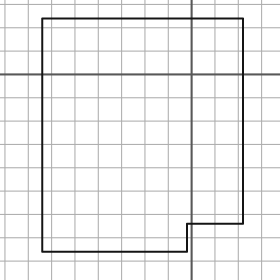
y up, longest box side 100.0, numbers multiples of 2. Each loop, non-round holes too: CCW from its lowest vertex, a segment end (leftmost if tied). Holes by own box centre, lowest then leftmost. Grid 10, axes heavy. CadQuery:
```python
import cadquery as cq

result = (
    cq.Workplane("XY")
    .moveTo(-64.0, -76.0)
    .lineTo(-2.0, -76.0)
    .lineTo(-2.0, -64.0)
    .lineTo(22.0, -64.0)
    .lineTo(22.0, 24.0)
    .lineTo(-64.0, 24.0)
    .close()
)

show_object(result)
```